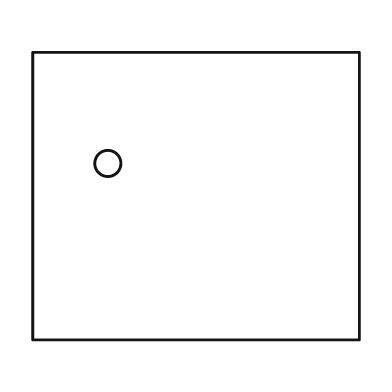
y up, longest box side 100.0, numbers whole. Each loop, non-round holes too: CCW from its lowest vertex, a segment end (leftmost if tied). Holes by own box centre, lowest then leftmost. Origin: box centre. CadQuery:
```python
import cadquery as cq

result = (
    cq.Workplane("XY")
    .moveTo(-50.0, -44.0)
    .lineTo(50.0, -44.0)
    .lineTo(50.0, 44.0)
    .lineTo(-50.0, 44.0)
    .close()
    .moveTo(-27.0, 10.0)
    .circle(4.0)
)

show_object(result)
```